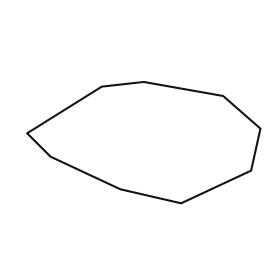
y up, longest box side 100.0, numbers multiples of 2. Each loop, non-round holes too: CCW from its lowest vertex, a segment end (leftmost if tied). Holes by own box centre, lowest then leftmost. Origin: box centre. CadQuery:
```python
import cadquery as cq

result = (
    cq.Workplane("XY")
    .moveTo(16.0, -26.0)
    .lineTo(46.0, -12.0)
    .lineTo(50.0, 6.0)
    .lineTo(34.0, 20.0)
    .lineTo(0.0, 26.0)
    .lineTo(-18.0, 24.0)
    .lineTo(-50.0, 4.0)
    .lineTo(-40.0, -6.0)
    .lineTo(-10.0, -20.0)
    .close()
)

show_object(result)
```